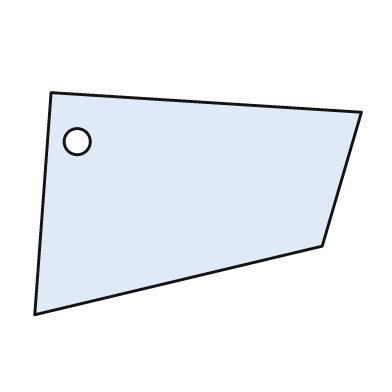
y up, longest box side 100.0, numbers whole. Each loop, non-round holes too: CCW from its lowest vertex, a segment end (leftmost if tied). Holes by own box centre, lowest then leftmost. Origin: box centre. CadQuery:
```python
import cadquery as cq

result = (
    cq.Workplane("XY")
    .moveTo(-50.0, -34.0)
    .lineTo(38.0, -13.0)
    .lineTo(50.0, 28.0)
    .lineTo(-45.0, 34.0)
    .close()
    .moveTo(-37.0, 19.0)
    .circle(4.0)
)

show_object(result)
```